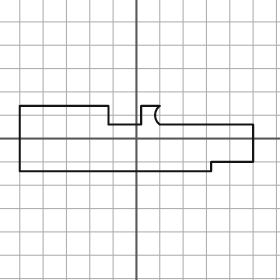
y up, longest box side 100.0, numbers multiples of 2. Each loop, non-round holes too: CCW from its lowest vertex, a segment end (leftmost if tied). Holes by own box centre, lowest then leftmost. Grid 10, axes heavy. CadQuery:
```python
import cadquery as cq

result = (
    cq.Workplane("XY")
    .moveTo(-50.0, -14.0)
    .lineTo(32.0, -14.0)
    .lineTo(32.0, -10.0)
    .lineTo(50.0, -10.0)
    .lineTo(50.0, 6.0)
    .lineTo(10.0, 6.0)
    .threePointArc((8.0, 10.0), (10.0, 14.0))
    .lineTo(2.0, 14.0)
    .lineTo(2.0, 6.0)
    .lineTo(-12.0, 6.0)
    .lineTo(-12.0, 14.0)
    .lineTo(-50.0, 14.0)
    .close()
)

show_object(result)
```